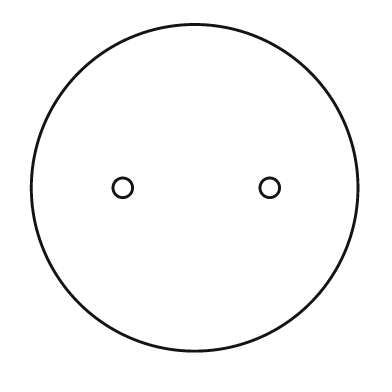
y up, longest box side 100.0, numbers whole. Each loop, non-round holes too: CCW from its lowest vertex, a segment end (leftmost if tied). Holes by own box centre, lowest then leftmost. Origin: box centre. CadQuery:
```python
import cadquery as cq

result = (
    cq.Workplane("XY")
    .moveTo(0.0, 0.0)
    .circle(50.0)
    .moveTo(-22.0, 0.0)
    .circle(3.0)
    .moveTo(23.0, 0.0)
    .circle(3.0)
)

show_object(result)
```